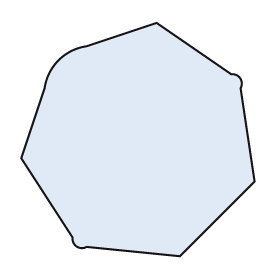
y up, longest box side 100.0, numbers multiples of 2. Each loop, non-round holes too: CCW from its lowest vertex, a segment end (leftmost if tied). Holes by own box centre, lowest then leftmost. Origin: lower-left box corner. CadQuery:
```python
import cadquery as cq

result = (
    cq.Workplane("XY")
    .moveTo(68.0, 0.0)
    .lineTo(100.0, 32.0)
    .lineTo(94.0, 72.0)
    .threePointArc((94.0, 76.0), (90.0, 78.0))
    .lineTo(58.0, 100.0)
    .lineTo(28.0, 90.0)
    .threePointArc((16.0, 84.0), (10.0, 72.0))
    .lineTo(0.0, 42.0)
    .lineTo(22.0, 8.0)
    .threePointArc((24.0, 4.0), (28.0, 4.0))
    .close()
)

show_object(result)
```